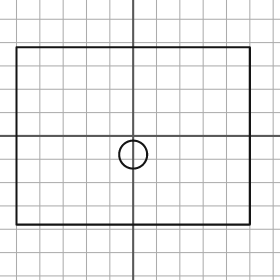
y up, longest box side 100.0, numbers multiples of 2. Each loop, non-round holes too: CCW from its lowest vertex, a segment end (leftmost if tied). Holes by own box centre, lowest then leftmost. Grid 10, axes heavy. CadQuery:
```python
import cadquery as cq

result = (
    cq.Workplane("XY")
    .moveTo(-50.0, -38.0)
    .lineTo(50.0, -38.0)
    .lineTo(50.0, 38.0)
    .lineTo(-50.0, 38.0)
    .close()
    .moveTo(0.0, -8.0)
    .circle(6.0)
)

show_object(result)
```